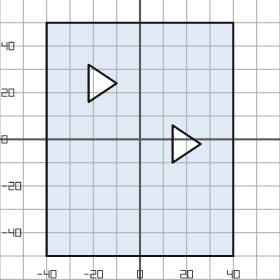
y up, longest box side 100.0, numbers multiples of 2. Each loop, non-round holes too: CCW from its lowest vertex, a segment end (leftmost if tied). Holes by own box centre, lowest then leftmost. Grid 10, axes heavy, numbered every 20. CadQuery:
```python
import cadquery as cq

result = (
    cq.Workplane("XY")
    .moveTo(-40.0, -50.0)
    .lineTo(40.0, -50.0)
    .lineTo(40.0, 50.0)
    .lineTo(-40.0, 50.0)
    .close()
    .moveTo(14.0, -10.0)
    .lineTo(26.0, -2.0)
    .lineTo(14.0, 6.0)
    .close()
    .moveTo(-22.0, 16.0)
    .lineTo(-10.0, 24.0)
    .lineTo(-22.0, 32.0)
    .close()
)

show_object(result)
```